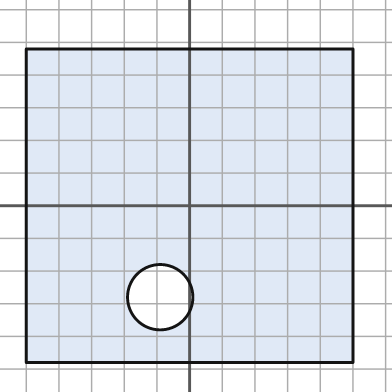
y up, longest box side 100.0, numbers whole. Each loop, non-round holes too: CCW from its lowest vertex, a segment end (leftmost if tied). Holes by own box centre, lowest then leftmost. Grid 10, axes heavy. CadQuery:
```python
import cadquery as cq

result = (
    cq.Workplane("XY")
    .moveTo(-50.0, -48.0)
    .lineTo(50.0, -48.0)
    .lineTo(50.0, 48.0)
    .lineTo(-50.0, 48.0)
    .close()
    .moveTo(-9.0, -28.0)
    .circle(10.0)
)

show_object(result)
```